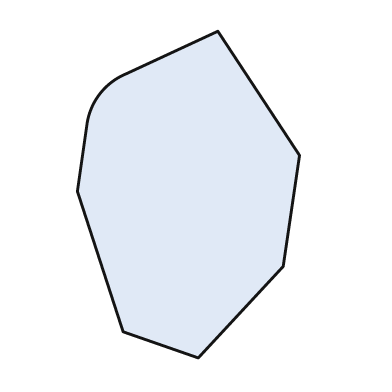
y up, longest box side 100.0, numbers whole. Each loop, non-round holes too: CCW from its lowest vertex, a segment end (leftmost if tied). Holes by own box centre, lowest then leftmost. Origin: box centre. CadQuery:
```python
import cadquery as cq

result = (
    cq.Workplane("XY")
    .moveTo(3.0, -50.0)
    .lineTo(29.0, -22.0)
    .lineTo(34.0, 12.0)
    .lineTo(9.0, 50.0)
    .lineTo(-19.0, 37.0)
    .threePointArc((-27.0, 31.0), (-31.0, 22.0))
    .lineTo(-34.0, 1.0)
    .lineTo(-20.0, -42.0)
    .close()
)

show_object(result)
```